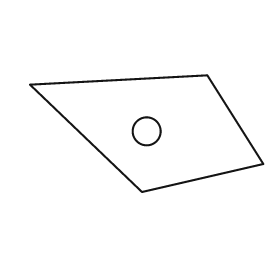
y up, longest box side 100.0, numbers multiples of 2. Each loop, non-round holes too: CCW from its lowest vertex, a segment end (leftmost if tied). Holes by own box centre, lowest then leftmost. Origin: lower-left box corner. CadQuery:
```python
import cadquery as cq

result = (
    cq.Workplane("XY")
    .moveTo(48.0, 0.0)
    .lineTo(100.0, 12.0)
    .lineTo(76.0, 50.0)
    .lineTo(0.0, 46.0)
    .close()
    .moveTo(50.0, 26.0)
    .circle(6.0)
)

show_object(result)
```